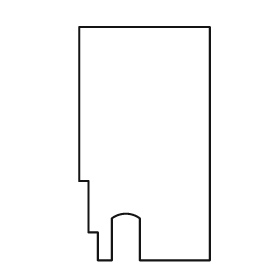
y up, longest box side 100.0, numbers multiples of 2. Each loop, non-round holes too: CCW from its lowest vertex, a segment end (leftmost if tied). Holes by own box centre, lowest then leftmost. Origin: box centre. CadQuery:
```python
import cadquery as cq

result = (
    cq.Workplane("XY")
    .moveTo(-20.0, -50.0)
    .lineTo(-14.0, -50.0)
    .lineTo(-14.0, -32.0)
    .threePointArc((-8.0, -30.0), (-2.0, -32.0))
    .lineTo(-2.0, -50.0)
    .lineTo(28.0, -50.0)
    .lineTo(28.0, 50.0)
    .lineTo(-28.0, 50.0)
    .lineTo(-28.0, -16.0)
    .lineTo(-24.0, -16.0)
    .lineTo(-24.0, -38.0)
    .lineTo(-20.0, -38.0)
    .close()
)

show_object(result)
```